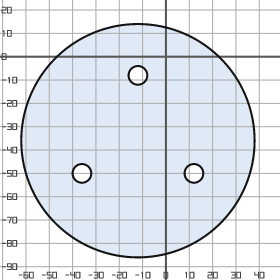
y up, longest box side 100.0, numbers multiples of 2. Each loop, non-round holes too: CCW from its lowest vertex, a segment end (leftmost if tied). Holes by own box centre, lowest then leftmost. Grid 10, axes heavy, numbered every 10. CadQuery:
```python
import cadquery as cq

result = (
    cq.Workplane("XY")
    .moveTo(-12.0, -36.0)
    .circle(50.0)
    .moveTo(-36.0, -50.0)
    .circle(4.0)
    .moveTo(12.0, -50.0)
    .circle(4.0)
    .moveTo(-12.0, -8.0)
    .circle(4.0)
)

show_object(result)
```